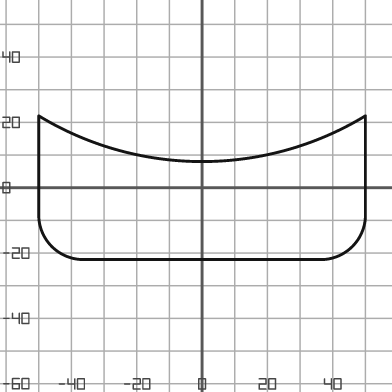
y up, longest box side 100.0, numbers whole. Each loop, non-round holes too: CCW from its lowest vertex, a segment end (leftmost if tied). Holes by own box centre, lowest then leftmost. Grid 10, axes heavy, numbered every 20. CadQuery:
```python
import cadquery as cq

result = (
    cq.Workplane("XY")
    .moveTo(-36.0, -22.0)
    .lineTo(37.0, -22.0)
    .threePointArc((46.0, -18.0), (50.0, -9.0))
    .lineTo(50.0, 22.0)
    .threePointArc((0.0, 8.0), (-50.0, 22.0))
    .lineTo(-50.0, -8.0)
    .threePointArc((-46.0, -18.0), (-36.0, -22.0))
    .close()
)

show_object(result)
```